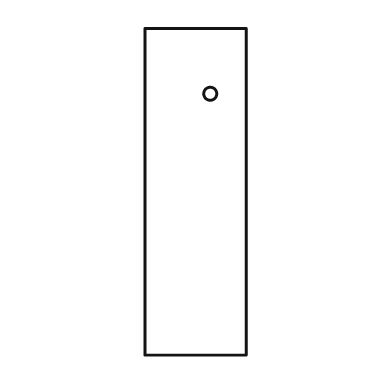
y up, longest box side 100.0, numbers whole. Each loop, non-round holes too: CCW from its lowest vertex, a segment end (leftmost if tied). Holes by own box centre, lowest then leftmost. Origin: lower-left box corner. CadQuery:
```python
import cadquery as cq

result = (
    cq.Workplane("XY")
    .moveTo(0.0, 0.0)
    .lineTo(31.0, 0.0)
    .lineTo(31.0, 100.0)
    .lineTo(0.0, 100.0)
    .close()
    .moveTo(20.0, 80.0)
    .circle(2.0)
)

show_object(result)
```